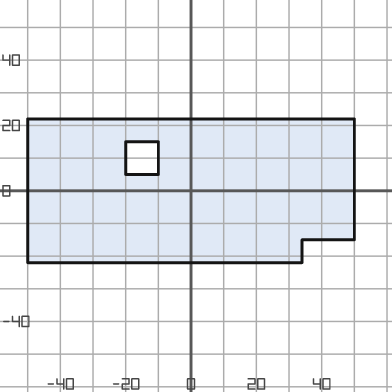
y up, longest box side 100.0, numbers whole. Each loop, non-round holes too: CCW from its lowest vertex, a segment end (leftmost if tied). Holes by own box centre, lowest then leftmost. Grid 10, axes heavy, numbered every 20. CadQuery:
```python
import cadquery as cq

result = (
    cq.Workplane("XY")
    .moveTo(-50.0, -22.0)
    .lineTo(34.0, -22.0)
    .lineTo(34.0, -15.0)
    .lineTo(50.0, -15.0)
    .lineTo(50.0, 22.0)
    .lineTo(-50.0, 22.0)
    .close()
    .moveTo(-20.0, 5.0)
    .lineTo(-10.0, 5.0)
    .lineTo(-10.0, 15.0)
    .lineTo(-20.0, 15.0)
    .close()
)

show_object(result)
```